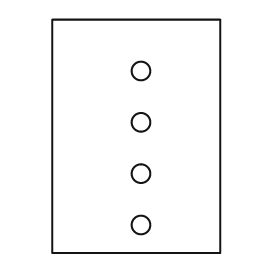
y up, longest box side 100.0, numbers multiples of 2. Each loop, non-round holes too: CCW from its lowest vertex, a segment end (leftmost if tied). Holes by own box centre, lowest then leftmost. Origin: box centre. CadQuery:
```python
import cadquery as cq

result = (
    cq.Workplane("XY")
    .moveTo(-36.0, -50.0)
    .lineTo(36.0, -50.0)
    .lineTo(36.0, 50.0)
    .lineTo(-36.0, 50.0)
    .close()
    .moveTo(2.0, -38.0)
    .circle(4.0)
    .moveTo(2.0, -16.0)
    .circle(4.0)
    .moveTo(2.0, 6.0)
    .circle(4.0)
    .moveTo(2.0, 28.0)
    .circle(4.0)
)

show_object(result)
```